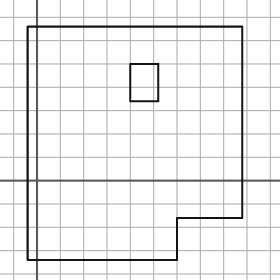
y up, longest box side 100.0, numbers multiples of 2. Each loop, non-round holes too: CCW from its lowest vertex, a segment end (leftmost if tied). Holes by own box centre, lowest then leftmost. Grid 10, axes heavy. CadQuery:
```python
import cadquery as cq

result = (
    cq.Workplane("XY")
    .moveTo(-4.0, -34.0)
    .lineTo(60.0, -34.0)
    .lineTo(60.0, -16.0)
    .lineTo(88.0, -16.0)
    .lineTo(88.0, 66.0)
    .lineTo(-4.0, 66.0)
    .close()
    .moveTo(40.0, 34.0)
    .lineTo(52.0, 34.0)
    .lineTo(52.0, 50.0)
    .lineTo(40.0, 50.0)
    .close()
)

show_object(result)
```